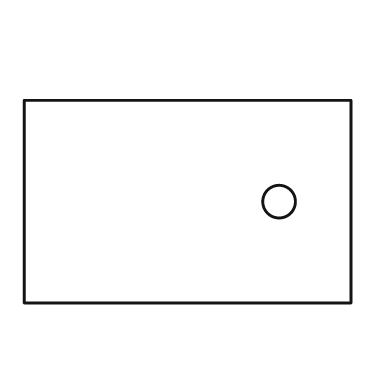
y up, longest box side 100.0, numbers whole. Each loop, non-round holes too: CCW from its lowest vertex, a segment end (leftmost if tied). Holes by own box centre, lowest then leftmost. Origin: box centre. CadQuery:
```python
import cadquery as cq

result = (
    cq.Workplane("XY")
    .moveTo(-50.0, -31.0)
    .lineTo(50.0, -31.0)
    .lineTo(50.0, 31.0)
    .lineTo(-50.0, 31.0)
    .close()
    .moveTo(28.0, 0.0)
    .circle(5.0)
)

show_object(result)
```